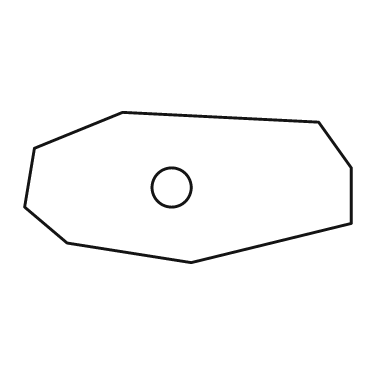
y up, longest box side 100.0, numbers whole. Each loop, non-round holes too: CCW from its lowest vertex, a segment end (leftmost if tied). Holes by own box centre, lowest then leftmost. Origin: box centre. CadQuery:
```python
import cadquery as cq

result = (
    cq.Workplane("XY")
    .moveTo(1.0, -23.0)
    .lineTo(50.0, -11.0)
    .lineTo(50.0, 6.0)
    .lineTo(40.0, 20.0)
    .lineTo(-20.0, 23.0)
    .lineTo(-47.0, 12.0)
    .lineTo(-50.0, -6.0)
    .lineTo(-37.0, -17.0)
    .close()
    .moveTo(-5.0, 0.0)
    .circle(6.0)
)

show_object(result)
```